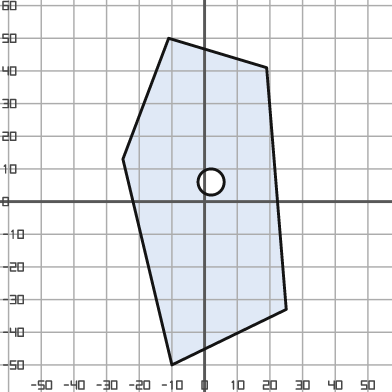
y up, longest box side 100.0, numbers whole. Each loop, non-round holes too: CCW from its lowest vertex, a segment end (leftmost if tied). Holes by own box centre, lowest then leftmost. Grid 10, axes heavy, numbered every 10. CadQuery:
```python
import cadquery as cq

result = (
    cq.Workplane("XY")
    .moveTo(-10.0, -50.0)
    .lineTo(25.0, -33.0)
    .lineTo(19.0, 41.0)
    .lineTo(-11.0, 50.0)
    .lineTo(-25.0, 13.0)
    .close()
    .moveTo(2.0, 6.0)
    .circle(4.0)
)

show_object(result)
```